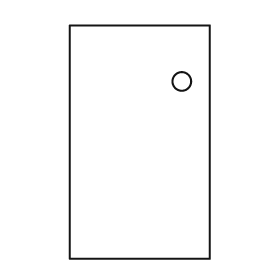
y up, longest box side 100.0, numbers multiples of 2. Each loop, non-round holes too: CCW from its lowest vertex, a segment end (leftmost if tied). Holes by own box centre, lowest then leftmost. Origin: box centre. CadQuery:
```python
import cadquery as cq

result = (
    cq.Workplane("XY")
    .moveTo(-30.0, -50.0)
    .lineTo(30.0, -50.0)
    .lineTo(30.0, 50.0)
    .lineTo(-30.0, 50.0)
    .close()
    .moveTo(18.0, 26.0)
    .circle(4.0)
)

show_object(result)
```